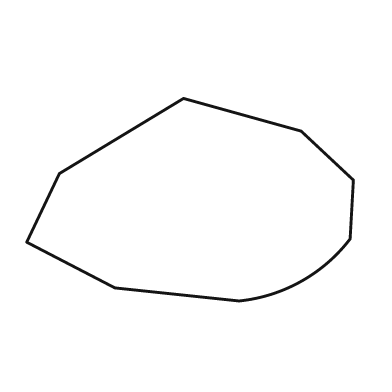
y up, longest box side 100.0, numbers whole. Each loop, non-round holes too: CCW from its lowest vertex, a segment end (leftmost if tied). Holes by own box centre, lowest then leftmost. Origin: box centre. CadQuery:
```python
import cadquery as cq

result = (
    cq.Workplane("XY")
    .moveTo(15.0, -31.0)
    .threePointArc((34.0, -25.0), (49.0, -12.0))
    .lineTo(50.0, 6.0)
    .lineTo(34.0, 21.0)
    .lineTo(-2.0, 31.0)
    .lineTo(-40.0, 8.0)
    .lineTo(-50.0, -13.0)
    .lineTo(-23.0, -27.0)
    .close()
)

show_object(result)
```